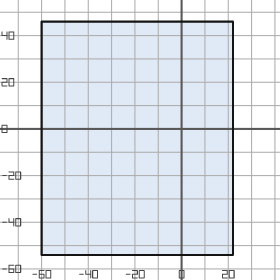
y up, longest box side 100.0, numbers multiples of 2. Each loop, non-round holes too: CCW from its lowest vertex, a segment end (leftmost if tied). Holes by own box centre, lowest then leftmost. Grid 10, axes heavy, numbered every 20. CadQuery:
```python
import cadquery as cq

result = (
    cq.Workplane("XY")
    .moveTo(-60.0, -54.0)
    .lineTo(22.0, -54.0)
    .lineTo(22.0, 46.0)
    .lineTo(-60.0, 46.0)
    .close()
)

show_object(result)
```